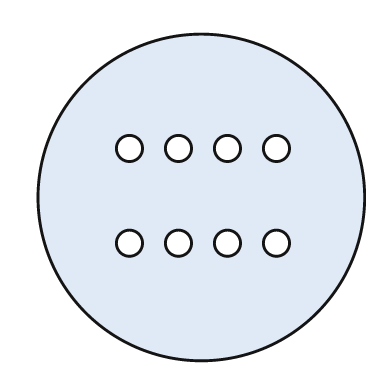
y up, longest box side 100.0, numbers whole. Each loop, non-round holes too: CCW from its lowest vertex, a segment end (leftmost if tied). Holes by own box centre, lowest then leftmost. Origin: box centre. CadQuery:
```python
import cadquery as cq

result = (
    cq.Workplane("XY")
    .moveTo(0.0, 0.0)
    .circle(50.0)
    .moveTo(-22.0, -14.0)
    .circle(4.0)
    .moveTo(-7.0, -14.0)
    .circle(4.0)
    .moveTo(8.0, -14.0)
    .circle(4.0)
    .moveTo(23.0, -14.0)
    .circle(4.0)
    .moveTo(-22.0, 15.0)
    .circle(4.0)
    .moveTo(-7.0, 15.0)
    .circle(4.0)
    .moveTo(8.0, 15.0)
    .circle(4.0)
    .moveTo(23.0, 15.0)
    .circle(4.0)
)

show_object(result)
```